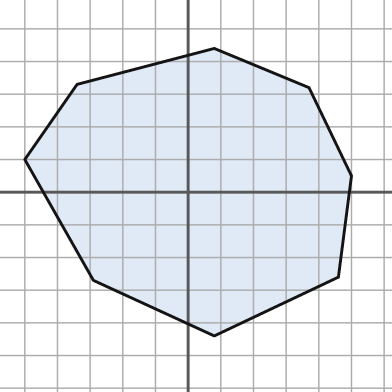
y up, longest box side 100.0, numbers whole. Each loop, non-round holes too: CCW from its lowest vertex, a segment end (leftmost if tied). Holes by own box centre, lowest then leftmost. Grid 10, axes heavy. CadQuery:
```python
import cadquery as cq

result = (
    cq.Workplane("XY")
    .moveTo(8.0, -44.0)
    .lineTo(46.0, -26.0)
    .lineTo(50.0, 5.0)
    .lineTo(37.0, 32.0)
    .lineTo(8.0, 44.0)
    .lineTo(-34.0, 33.0)
    .lineTo(-50.0, 10.0)
    .lineTo(-29.0, -27.0)
    .close()
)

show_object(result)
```